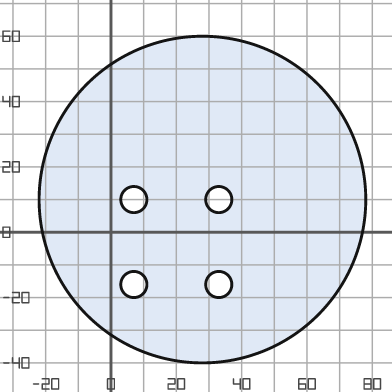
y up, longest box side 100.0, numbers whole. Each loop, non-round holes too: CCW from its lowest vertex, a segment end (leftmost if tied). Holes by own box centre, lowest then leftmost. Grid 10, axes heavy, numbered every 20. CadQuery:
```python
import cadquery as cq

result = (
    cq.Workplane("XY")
    .moveTo(28.0, 10.0)
    .circle(50.0)
    .moveTo(7.0, -16.0)
    .circle(4.0)
    .moveTo(33.0, -16.0)
    .circle(4.0)
    .moveTo(7.0, 10.0)
    .circle(4.0)
    .moveTo(33.0, 10.0)
    .circle(4.0)
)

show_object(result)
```